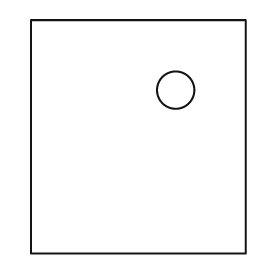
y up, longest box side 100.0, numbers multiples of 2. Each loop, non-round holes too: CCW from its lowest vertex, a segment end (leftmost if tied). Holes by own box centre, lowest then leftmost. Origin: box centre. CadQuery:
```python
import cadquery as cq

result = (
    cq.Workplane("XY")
    .moveTo(-46.0, -50.0)
    .lineTo(46.0, -50.0)
    .lineTo(46.0, 50.0)
    .lineTo(-46.0, 50.0)
    .close()
    .moveTo(16.0, 20.0)
    .circle(8.0)
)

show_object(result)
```